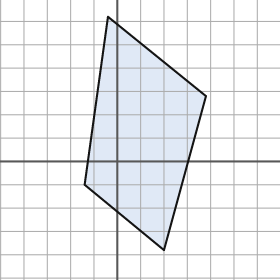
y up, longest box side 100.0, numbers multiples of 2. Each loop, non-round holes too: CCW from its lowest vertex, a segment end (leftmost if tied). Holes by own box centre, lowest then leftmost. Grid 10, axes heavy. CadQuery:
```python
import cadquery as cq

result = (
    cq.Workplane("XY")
    .moveTo(20.0, -38.0)
    .lineTo(38.0, 28.0)
    .lineTo(-4.0, 62.0)
    .lineTo(-14.0, -10.0)
    .close()
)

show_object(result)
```